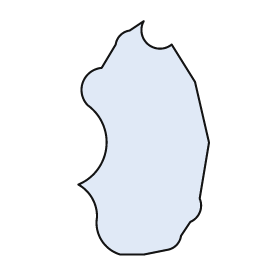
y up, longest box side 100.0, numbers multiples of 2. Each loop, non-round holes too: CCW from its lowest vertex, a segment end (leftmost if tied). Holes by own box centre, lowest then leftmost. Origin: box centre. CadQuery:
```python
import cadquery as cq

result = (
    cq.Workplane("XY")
    .moveTo(-10.0, -50.0)
    .lineTo(0.0, -50.0)
    .lineTo(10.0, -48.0)
    .threePointArc((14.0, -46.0), (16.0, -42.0))
    .lineTo(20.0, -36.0)
    .threePointArc((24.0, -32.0), (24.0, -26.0))
    .lineTo(28.0, -2.0)
    .lineTo(22.0, 24.0)
    .lineTo(12.0, 40.0)
    .threePointArc((2.0, 40.0), (0.0, 50.0))
    .lineTo(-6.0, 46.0)
    .threePointArc((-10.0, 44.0), (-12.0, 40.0))
    .lineTo(-18.0, 30.0)
    .threePointArc((-26.0, 24.0), (-24.0, 14.0))
    .threePointArc((-16.0, -4.0), (-28.0, -20.0))
    .threePointArc((-22.0, -26.0), (-20.0, -34.0))
    .threePointArc((-18.0, -44.0), (-10.0, -50.0))
    .close()
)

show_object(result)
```